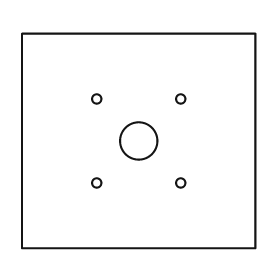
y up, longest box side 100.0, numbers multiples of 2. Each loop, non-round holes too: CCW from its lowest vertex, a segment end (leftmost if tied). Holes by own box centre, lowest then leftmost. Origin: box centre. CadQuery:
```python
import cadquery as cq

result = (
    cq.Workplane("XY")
    .moveTo(-50.0, -46.0)
    .lineTo(50.0, -46.0)
    .lineTo(50.0, 46.0)
    .lineTo(-50.0, 46.0)
    .close()
    .moveTo(-18.0, -18.0)
    .circle(2.0)
    .moveTo(18.0, -18.0)
    .circle(2.0)
    .moveTo(0.0, 0.0)
    .circle(8.0)
    .moveTo(-18.0, 18.0)
    .circle(2.0)
    .moveTo(18.0, 18.0)
    .circle(2.0)
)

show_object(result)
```